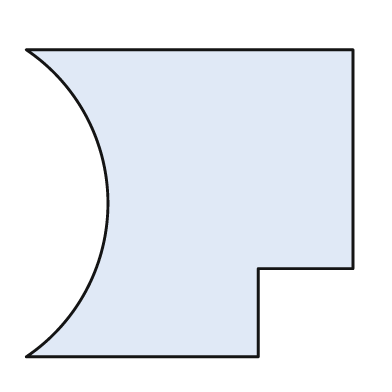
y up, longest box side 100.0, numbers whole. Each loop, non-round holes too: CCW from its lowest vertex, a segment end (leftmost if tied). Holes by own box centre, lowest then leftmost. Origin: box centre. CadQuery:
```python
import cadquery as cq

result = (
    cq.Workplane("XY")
    .moveTo(-50.0, -47.0)
    .lineTo(21.0, -47.0)
    .lineTo(21.0, -20.0)
    .lineTo(50.0, -20.0)
    .lineTo(50.0, 47.0)
    .lineTo(-50.0, 47.0)
    .threePointArc((-25.0, 0.0), (-50.0, -47.0))
    .close()
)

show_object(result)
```